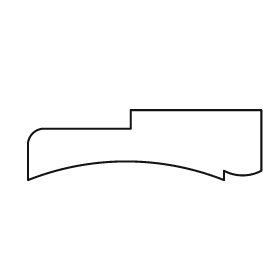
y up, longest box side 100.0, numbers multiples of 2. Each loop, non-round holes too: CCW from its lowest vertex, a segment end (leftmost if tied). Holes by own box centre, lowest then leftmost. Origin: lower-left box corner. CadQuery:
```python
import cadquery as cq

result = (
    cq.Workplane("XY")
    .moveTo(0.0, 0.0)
    .threePointArc((42.0, 8.0), (84.0, 0.0))
    .lineTo(84.0, 4.0)
    .threePointArc((92.0, 2.0), (100.0, 4.0))
    .lineTo(100.0, 30.0)
    .lineTo(44.0, 30.0)
    .lineTo(44.0, 22.0)
    .lineTo(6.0, 22.0)
    .threePointArc((2.0, 20.0), (0.0, 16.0))
    .close()
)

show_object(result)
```